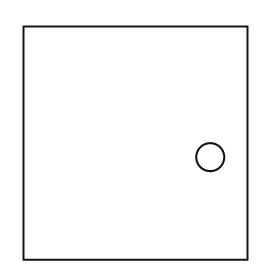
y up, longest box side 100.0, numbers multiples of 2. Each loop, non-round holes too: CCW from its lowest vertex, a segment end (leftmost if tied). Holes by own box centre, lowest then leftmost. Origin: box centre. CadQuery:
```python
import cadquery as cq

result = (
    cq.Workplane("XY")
    .moveTo(-48.0, -50.0)
    .lineTo(48.0, -50.0)
    .lineTo(48.0, 50.0)
    .lineTo(-48.0, 50.0)
    .close()
    .moveTo(32.0, -6.0)
    .circle(6.0)
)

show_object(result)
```